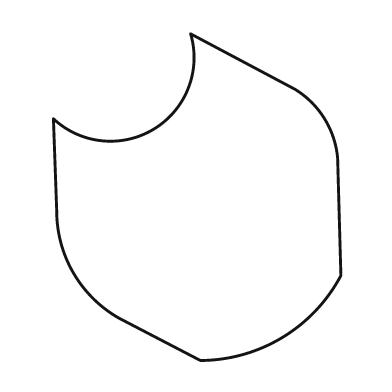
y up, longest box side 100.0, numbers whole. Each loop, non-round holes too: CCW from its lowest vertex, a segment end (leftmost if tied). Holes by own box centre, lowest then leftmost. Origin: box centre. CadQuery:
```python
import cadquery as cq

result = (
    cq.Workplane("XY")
    .moveTo(1.0, -50.0)
    .threePointArc((26.0, -43.0), (44.0, -24.0))
    .lineTo(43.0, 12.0)
    .threePointArc((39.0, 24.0), (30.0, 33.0))
    .lineTo(-2.0, 50.0)
    .threePointArc((-13.0, 21.0), (-44.0, 24.0))
    .lineTo(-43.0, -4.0)
    .threePointArc((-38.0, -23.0), (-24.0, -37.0))
    .close()
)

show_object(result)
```